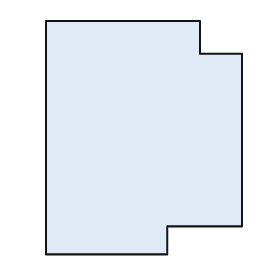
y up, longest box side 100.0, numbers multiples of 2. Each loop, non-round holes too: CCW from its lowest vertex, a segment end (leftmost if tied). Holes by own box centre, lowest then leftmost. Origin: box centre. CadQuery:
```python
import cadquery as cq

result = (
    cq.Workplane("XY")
    .moveTo(-42.0, -50.0)
    .lineTo(10.0, -50.0)
    .lineTo(10.0, -38.0)
    .lineTo(42.0, -38.0)
    .lineTo(42.0, 36.0)
    .lineTo(24.0, 36.0)
    .lineTo(24.0, 50.0)
    .lineTo(-42.0, 50.0)
    .close()
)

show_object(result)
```